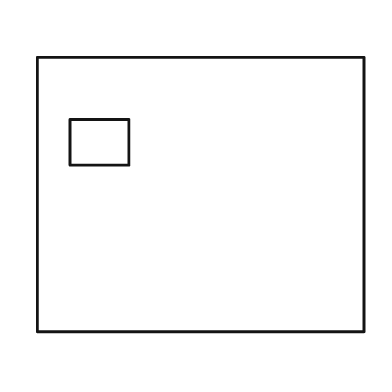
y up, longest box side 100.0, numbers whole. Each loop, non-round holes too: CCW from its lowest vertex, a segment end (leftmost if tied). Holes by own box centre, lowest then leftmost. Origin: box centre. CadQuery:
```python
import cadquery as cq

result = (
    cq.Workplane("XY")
    .moveTo(-50.0, -42.0)
    .lineTo(50.0, -42.0)
    .lineTo(50.0, 42.0)
    .lineTo(-50.0, 42.0)
    .close()
    .moveTo(-40.0, 9.0)
    .lineTo(-22.0, 9.0)
    .lineTo(-22.0, 23.0)
    .lineTo(-40.0, 23.0)
    .close()
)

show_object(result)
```